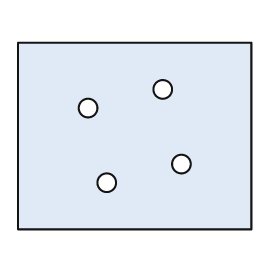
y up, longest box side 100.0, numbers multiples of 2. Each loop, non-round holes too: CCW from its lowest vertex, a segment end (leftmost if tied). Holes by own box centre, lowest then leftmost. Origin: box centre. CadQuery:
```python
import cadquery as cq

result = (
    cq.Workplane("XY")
    .moveTo(-50.0, -40.0)
    .lineTo(50.0, -40.0)
    .lineTo(50.0, 40.0)
    .lineTo(-50.0, 40.0)
    .close()
    .moveTo(-12.0, -20.0)
    .circle(4.0)
    .moveTo(20.0, -12.0)
    .circle(4.0)
    .moveTo(-20.0, 12.0)
    .circle(4.0)
    .moveTo(12.0, 20.0)
    .circle(4.0)
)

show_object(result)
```